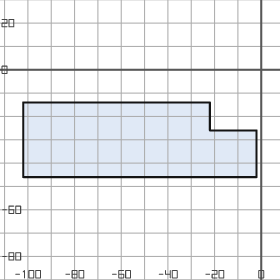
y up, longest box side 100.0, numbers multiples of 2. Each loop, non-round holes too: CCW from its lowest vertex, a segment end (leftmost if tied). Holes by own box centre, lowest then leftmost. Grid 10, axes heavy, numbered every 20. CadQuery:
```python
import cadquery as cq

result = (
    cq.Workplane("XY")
    .moveTo(-102.0, -46.0)
    .lineTo(-2.0, -46.0)
    .lineTo(-2.0, -26.0)
    .lineTo(-22.0, -26.0)
    .lineTo(-22.0, -14.0)
    .lineTo(-102.0, -14.0)
    .close()
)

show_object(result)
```